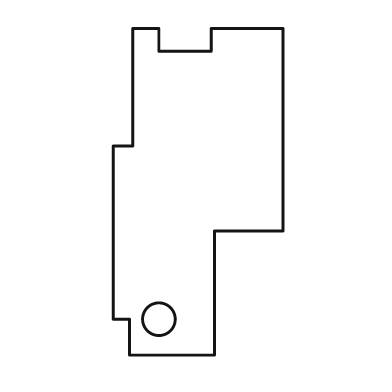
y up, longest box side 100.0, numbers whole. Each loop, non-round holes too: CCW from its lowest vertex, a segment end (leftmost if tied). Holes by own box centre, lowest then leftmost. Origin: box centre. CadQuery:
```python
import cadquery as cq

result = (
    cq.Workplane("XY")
    .moveTo(-21.0, -50.0)
    .lineTo(5.0, -50.0)
    .lineTo(5.0, -12.0)
    .lineTo(26.0, -12.0)
    .lineTo(26.0, 50.0)
    .lineTo(4.0, 50.0)
    .lineTo(4.0, 43.0)
    .lineTo(-12.0, 43.0)
    .lineTo(-12.0, 50.0)
    .lineTo(-20.0, 50.0)
    .lineTo(-20.0, 14.0)
    .lineTo(-26.0, 14.0)
    .lineTo(-26.0, -39.0)
    .lineTo(-21.0, -39.0)
    .close()
    .moveTo(-12.0, -39.0)
    .circle(5.0)
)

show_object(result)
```